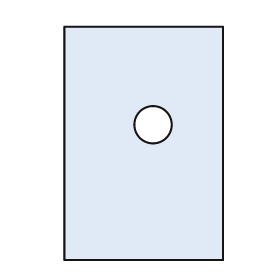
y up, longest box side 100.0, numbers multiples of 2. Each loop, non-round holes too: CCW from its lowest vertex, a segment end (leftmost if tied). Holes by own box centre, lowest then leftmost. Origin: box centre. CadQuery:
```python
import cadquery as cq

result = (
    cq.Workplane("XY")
    .moveTo(-34.0, -50.0)
    .lineTo(34.0, -50.0)
    .lineTo(34.0, 50.0)
    .lineTo(-34.0, 50.0)
    .close()
    .moveTo(4.0, 8.0)
    .circle(8.0)
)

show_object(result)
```